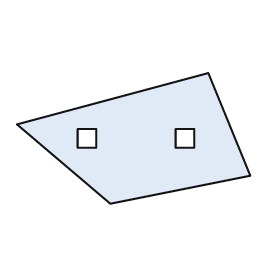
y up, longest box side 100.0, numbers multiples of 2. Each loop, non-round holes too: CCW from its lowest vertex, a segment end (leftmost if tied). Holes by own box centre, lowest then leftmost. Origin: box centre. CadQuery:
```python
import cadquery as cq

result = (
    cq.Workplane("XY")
    .moveTo(-10.0, -28.0)
    .lineTo(50.0, -16.0)
    .lineTo(32.0, 28.0)
    .lineTo(-50.0, 6.0)
    .close()
    .moveTo(-24.0, -4.0)
    .lineTo(-16.0, -4.0)
    .lineTo(-16.0, 4.0)
    .lineTo(-24.0, 4.0)
    .close()
    .moveTo(18.0, -4.0)
    .lineTo(26.0, -4.0)
    .lineTo(26.0, 4.0)
    .lineTo(18.0, 4.0)
    .close()
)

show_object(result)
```